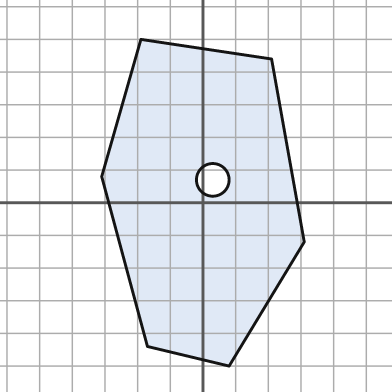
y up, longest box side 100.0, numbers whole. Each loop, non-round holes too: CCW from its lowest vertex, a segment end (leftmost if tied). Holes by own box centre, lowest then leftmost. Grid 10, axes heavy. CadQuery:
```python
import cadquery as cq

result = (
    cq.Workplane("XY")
    .moveTo(8.0, -50.0)
    .lineTo(31.0, -12.0)
    .lineTo(21.0, 44.0)
    .lineTo(-19.0, 50.0)
    .lineTo(-31.0, 8.0)
    .lineTo(-17.0, -44.0)
    .close()
    .moveTo(3.0, 7.0)
    .circle(5.0)
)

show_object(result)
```